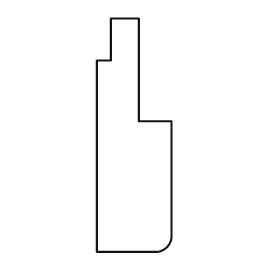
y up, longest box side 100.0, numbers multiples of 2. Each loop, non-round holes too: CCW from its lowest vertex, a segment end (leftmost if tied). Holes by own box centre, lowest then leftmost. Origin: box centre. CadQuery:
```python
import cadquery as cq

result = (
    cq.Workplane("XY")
    .moveTo(-16.0, -50.0)
    .lineTo(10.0, -50.0)
    .threePointArc((14.0, -48.0), (16.0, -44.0))
    .lineTo(16.0, 6.0)
    .lineTo(2.0, 6.0)
    .lineTo(2.0, 50.0)
    .lineTo(-10.0, 50.0)
    .lineTo(-10.0, 32.0)
    .lineTo(-16.0, 32.0)
    .close()
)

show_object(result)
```